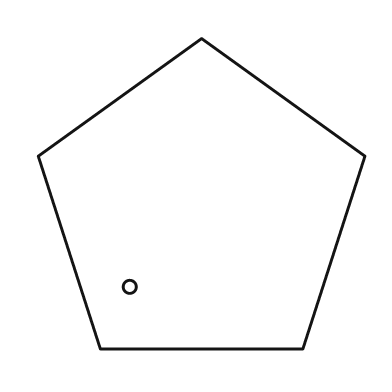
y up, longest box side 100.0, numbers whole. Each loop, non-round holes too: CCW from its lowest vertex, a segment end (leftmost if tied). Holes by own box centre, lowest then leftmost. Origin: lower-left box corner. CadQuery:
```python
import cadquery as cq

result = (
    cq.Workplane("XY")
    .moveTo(19.0, 0.0)
    .lineTo(81.0, 0.0)
    .lineTo(100.0, 59.0)
    .lineTo(50.0, 95.0)
    .lineTo(0.0, 59.0)
    .close()
    .moveTo(28.0, 19.0)
    .circle(2.0)
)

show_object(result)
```